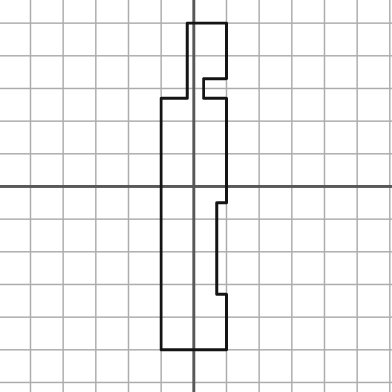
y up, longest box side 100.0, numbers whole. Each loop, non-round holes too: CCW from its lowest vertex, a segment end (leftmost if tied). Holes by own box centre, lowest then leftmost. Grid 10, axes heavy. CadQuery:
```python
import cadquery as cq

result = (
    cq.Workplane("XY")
    .moveTo(-10.0, -50.0)
    .lineTo(10.0, -50.0)
    .lineTo(10.0, -33.0)
    .lineTo(7.0, -33.0)
    .lineTo(7.0, -5.0)
    .lineTo(10.0, -5.0)
    .lineTo(10.0, 27.0)
    .lineTo(3.0, 27.0)
    .lineTo(3.0, 33.0)
    .lineTo(10.0, 33.0)
    .lineTo(10.0, 50.0)
    .lineTo(-2.0, 50.0)
    .lineTo(-2.0, 27.0)
    .lineTo(-10.0, 27.0)
    .close()
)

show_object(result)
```